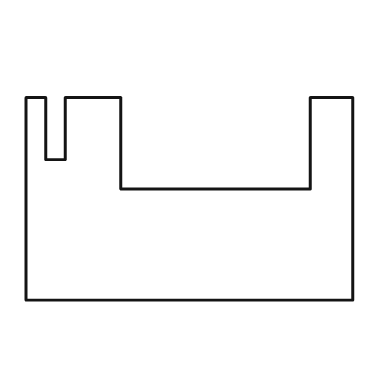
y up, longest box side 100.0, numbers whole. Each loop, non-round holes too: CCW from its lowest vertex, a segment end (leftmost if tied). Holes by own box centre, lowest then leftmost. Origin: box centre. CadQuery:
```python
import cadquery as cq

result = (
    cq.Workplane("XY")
    .moveTo(-50.0, -31.0)
    .lineTo(50.0, -31.0)
    .lineTo(50.0, 31.0)
    .lineTo(37.0, 31.0)
    .lineTo(37.0, 3.0)
    .lineTo(-21.0, 3.0)
    .lineTo(-21.0, 31.0)
    .lineTo(-38.0, 31.0)
    .lineTo(-38.0, 12.0)
    .lineTo(-44.0, 12.0)
    .lineTo(-44.0, 31.0)
    .lineTo(-50.0, 31.0)
    .close()
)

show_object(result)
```